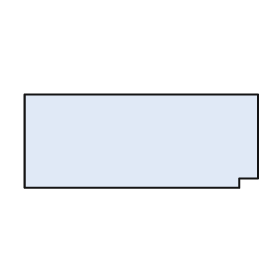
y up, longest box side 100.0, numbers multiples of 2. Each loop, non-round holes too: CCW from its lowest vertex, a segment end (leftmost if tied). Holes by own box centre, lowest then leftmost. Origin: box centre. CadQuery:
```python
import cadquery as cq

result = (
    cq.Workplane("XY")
    .moveTo(-50.0, -20.0)
    .lineTo(42.0, -20.0)
    .lineTo(42.0, -16.0)
    .lineTo(50.0, -16.0)
    .lineTo(50.0, 20.0)
    .lineTo(-50.0, 20.0)
    .close()
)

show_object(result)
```